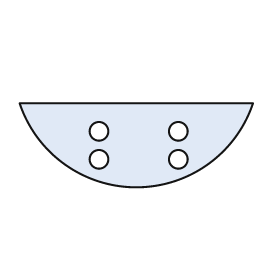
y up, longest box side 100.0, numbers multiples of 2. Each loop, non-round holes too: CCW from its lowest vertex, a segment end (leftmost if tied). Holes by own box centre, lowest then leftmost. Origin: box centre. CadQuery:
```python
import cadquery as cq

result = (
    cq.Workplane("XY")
    .moveTo(-50.0, 18.0)
    .threePointArc((0.0, -18.0), (50.0, 18.0))
    .close()
    .moveTo(-16.0, -6.0)
    .circle(4.0)
    .moveTo(18.0, -6.0)
    .circle(4.0)
    .moveTo(-16.0, 6.0)
    .circle(4.0)
    .moveTo(18.0, 6.0)
    .circle(4.0)
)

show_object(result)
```